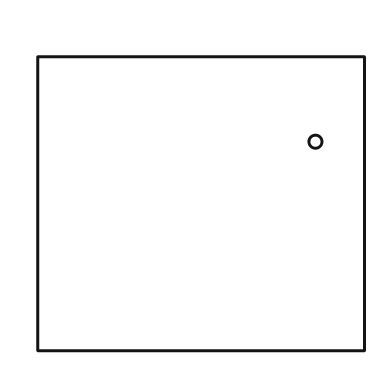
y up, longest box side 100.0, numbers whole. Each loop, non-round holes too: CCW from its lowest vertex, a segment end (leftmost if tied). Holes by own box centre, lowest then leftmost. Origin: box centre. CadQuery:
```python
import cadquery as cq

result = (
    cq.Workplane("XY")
    .moveTo(-50.0, -45.0)
    .lineTo(50.0, -45.0)
    .lineTo(50.0, 45.0)
    .lineTo(-50.0, 45.0)
    .close()
    .moveTo(35.0, 19.0)
    .circle(2.0)
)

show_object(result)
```